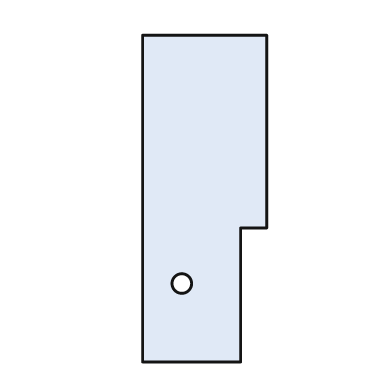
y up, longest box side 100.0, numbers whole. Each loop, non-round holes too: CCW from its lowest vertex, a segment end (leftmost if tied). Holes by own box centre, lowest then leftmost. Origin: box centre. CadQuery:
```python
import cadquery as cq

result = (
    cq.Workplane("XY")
    .moveTo(-19.0, -50.0)
    .lineTo(11.0, -50.0)
    .lineTo(11.0, -9.0)
    .lineTo(19.0, -9.0)
    .lineTo(19.0, 50.0)
    .lineTo(-19.0, 50.0)
    .close()
    .moveTo(-7.0, -26.0)
    .circle(3.0)
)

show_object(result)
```